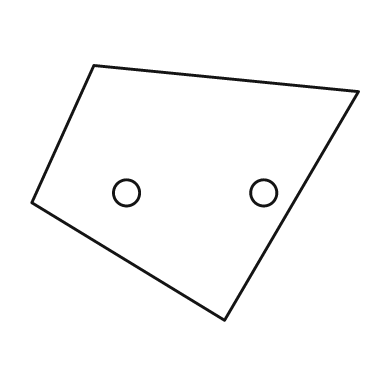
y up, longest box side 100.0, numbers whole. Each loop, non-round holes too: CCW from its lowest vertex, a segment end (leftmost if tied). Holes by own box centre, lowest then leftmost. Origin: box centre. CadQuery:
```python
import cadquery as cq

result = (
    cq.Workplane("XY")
    .moveTo(9.0, -39.0)
    .lineTo(50.0, 31.0)
    .lineTo(-31.0, 39.0)
    .lineTo(-50.0, -3.0)
    .close()
    .moveTo(-21.0, 0.0)
    .circle(4.0)
    .moveTo(21.0, 0.0)
    .circle(4.0)
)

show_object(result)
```